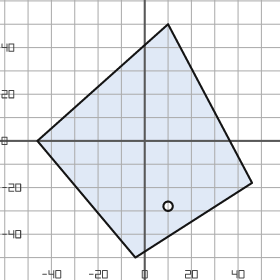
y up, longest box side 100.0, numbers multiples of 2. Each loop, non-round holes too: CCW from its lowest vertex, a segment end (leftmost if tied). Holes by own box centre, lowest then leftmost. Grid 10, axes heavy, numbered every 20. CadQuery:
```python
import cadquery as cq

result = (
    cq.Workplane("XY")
    .moveTo(-4.0, -50.0)
    .lineTo(46.0, -18.0)
    .lineTo(10.0, 50.0)
    .lineTo(-46.0, 0.0)
    .close()
    .moveTo(10.0, -28.0)
    .circle(2.0)
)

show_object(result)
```